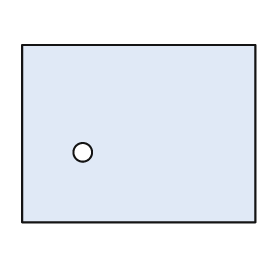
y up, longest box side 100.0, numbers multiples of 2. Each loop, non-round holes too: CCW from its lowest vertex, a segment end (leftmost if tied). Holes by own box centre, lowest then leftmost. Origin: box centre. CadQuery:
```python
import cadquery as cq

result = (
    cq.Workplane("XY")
    .moveTo(-50.0, -38.0)
    .lineTo(50.0, -38.0)
    .lineTo(50.0, 38.0)
    .lineTo(-50.0, 38.0)
    .close()
    .moveTo(-24.0, -8.0)
    .circle(4.0)
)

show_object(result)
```